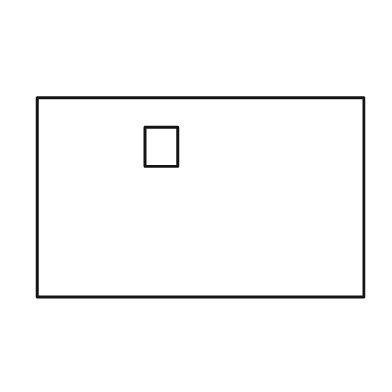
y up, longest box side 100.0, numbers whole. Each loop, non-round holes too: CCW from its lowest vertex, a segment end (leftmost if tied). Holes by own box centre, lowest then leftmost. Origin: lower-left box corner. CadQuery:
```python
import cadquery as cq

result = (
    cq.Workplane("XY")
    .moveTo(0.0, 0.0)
    .lineTo(100.0, 0.0)
    .lineTo(100.0, 61.0)
    .lineTo(0.0, 61.0)
    .close()
    .moveTo(33.0, 40.0)
    .lineTo(43.0, 40.0)
    .lineTo(43.0, 52.0)
    .lineTo(33.0, 52.0)
    .close()
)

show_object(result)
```